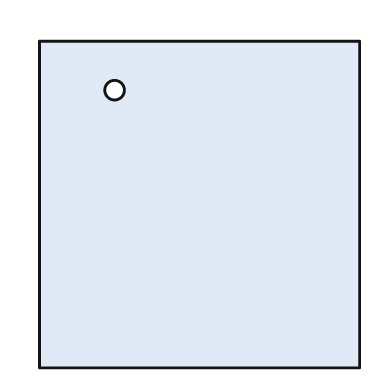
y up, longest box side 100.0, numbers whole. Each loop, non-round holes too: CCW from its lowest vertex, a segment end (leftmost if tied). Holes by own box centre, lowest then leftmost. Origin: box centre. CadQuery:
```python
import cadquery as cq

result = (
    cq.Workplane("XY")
    .moveTo(-49.0, -50.0)
    .lineTo(49.0, -50.0)
    .lineTo(49.0, 50.0)
    .lineTo(-49.0, 50.0)
    .close()
    .moveTo(-26.0, 35.0)
    .circle(3.0)
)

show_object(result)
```